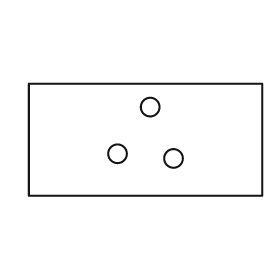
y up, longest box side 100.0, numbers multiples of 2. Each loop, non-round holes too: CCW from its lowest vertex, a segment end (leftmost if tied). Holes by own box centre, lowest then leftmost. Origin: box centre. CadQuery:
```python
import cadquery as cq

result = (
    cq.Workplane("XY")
    .moveTo(-50.0, -24.0)
    .lineTo(50.0, -24.0)
    .lineTo(50.0, 24.0)
    .lineTo(-50.0, 24.0)
    .close()
    .moveTo(12.0, -8.0)
    .circle(4.0)
    .moveTo(-12.0, -6.0)
    .circle(4.0)
    .moveTo(2.0, 14.0)
    .circle(4.0)
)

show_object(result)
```